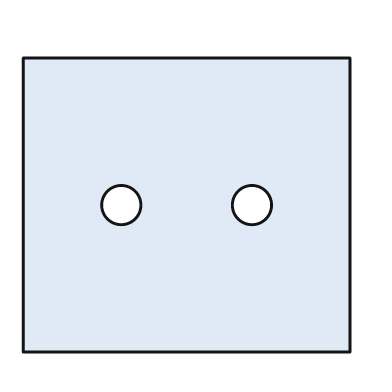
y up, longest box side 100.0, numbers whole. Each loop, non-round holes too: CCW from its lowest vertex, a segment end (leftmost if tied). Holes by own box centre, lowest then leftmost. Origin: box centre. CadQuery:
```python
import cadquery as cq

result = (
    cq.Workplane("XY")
    .moveTo(-50.0, -45.0)
    .lineTo(50.0, -45.0)
    .lineTo(50.0, 45.0)
    .lineTo(-50.0, 45.0)
    .close()
    .moveTo(-20.0, 0.0)
    .circle(6.0)
    .moveTo(20.0, 0.0)
    .circle(6.0)
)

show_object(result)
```